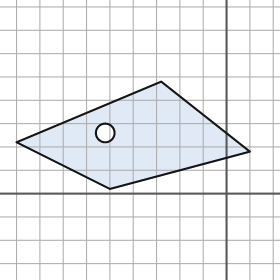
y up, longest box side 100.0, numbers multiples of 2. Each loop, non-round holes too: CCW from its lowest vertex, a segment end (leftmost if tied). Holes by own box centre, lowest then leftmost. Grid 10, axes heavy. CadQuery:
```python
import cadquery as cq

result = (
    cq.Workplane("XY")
    .moveTo(-50.0, 2.0)
    .lineTo(10.0, 18.0)
    .lineTo(-28.0, 48.0)
    .lineTo(-90.0, 22.0)
    .close()
    .moveTo(-52.0, 26.0)
    .circle(4.0)
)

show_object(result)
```